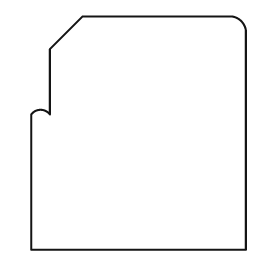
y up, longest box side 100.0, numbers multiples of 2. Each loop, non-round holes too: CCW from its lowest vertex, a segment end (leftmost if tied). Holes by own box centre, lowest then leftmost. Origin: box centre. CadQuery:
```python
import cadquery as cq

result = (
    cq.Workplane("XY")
    .moveTo(-46.0, -50.0)
    .lineTo(46.0, -50.0)
    .lineTo(46.0, 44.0)
    .threePointArc((44.0, 48.0), (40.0, 50.0))
    .lineTo(-24.0, 50.0)
    .lineTo(-38.0, 36.0)
    .lineTo(-38.0, 8.0)
    .threePointArc((-42.0, 10.0), (-46.0, 8.0))
    .close()
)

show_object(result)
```